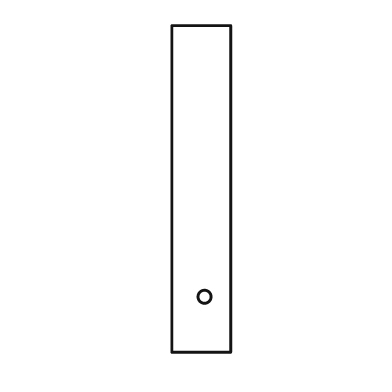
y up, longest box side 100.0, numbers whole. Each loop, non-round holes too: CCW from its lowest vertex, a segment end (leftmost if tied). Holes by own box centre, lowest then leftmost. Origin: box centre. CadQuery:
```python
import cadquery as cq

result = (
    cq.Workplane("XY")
    .moveTo(-9.0, -50.0)
    .lineTo(9.0, -50.0)
    .lineTo(9.0, 50.0)
    .lineTo(-9.0, 50.0)
    .close()
    .moveTo(1.0, -33.0)
    .circle(2.0)
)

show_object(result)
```